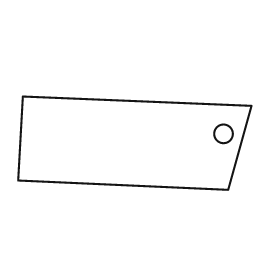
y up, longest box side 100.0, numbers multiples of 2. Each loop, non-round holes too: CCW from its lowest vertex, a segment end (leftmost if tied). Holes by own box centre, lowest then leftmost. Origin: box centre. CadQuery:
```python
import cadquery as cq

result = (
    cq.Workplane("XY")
    .moveTo(40.0, -20.0)
    .lineTo(50.0, 16.0)
    .lineTo(-48.0, 20.0)
    .lineTo(-50.0, -16.0)
    .close()
    .moveTo(38.0, 4.0)
    .circle(4.0)
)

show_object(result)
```